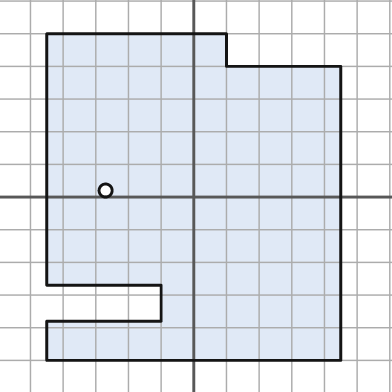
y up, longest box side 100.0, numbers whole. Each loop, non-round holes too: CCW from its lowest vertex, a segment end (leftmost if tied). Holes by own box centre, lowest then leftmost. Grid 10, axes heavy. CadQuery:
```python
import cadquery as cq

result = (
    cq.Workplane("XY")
    .moveTo(-45.0, -50.0)
    .lineTo(45.0, -50.0)
    .lineTo(45.0, 40.0)
    .lineTo(10.0, 40.0)
    .lineTo(10.0, 50.0)
    .lineTo(-45.0, 50.0)
    .lineTo(-45.0, -27.0)
    .lineTo(-10.0, -27.0)
    .lineTo(-10.0, -38.0)
    .lineTo(-45.0, -38.0)
    .close()
    .moveTo(-27.0, 2.0)
    .circle(2.0)
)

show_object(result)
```